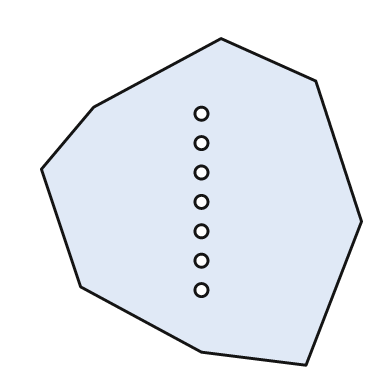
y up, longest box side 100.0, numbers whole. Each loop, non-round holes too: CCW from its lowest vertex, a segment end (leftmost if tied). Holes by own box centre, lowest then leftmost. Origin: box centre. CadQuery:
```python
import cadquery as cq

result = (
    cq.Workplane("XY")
    .moveTo(32.0, -50.0)
    .lineTo(49.0, -6.0)
    .lineTo(35.0, 37.0)
    .lineTo(6.0, 50.0)
    .lineTo(-33.0, 29.0)
    .lineTo(-49.0, 10.0)
    .lineTo(-37.0, -26.0)
    .lineTo(0.0, -46.0)
    .close()
    .moveTo(0.0, -27.0)
    .circle(2.0)
    .moveTo(0.0, -18.0)
    .circle(2.0)
    .moveTo(0.0, -9.0)
    .circle(2.0)
    .moveTo(0.0, 0.0)
    .circle(2.0)
    .moveTo(0.0, 9.0)
    .circle(2.0)
    .moveTo(0.0, 18.0)
    .circle(2.0)
    .moveTo(0.0, 27.0)
    .circle(2.0)
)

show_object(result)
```